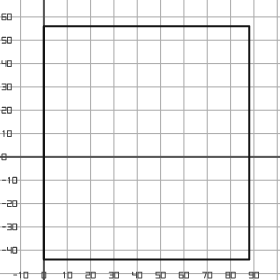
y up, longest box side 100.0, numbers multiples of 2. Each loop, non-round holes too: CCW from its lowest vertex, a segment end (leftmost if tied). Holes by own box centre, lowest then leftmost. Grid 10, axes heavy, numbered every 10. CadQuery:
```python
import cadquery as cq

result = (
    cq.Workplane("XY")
    .moveTo(0.0, -44.0)
    .lineTo(88.0, -44.0)
    .lineTo(88.0, 56.0)
    .lineTo(0.0, 56.0)
    .close()
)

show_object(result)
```